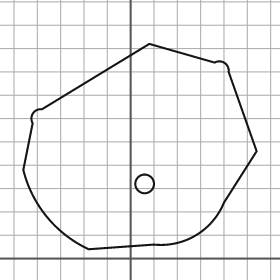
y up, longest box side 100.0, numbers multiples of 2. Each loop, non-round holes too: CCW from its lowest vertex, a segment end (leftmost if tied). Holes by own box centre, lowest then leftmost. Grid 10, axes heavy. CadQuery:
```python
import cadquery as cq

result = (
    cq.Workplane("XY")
    .moveTo(-18.0, 4.0)
    .lineTo(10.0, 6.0)
    .threePointArc((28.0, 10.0), (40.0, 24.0))
    .lineTo(54.0, 46.0)
    .lineTo(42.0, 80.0)
    .threePointArc((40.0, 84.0), (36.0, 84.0))
    .lineTo(8.0, 92.0)
    .lineTo(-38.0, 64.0)
    .threePointArc((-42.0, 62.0), (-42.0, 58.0))
    .lineTo(-46.0, 38.0)
    .threePointArc((-36.0, 18.0), (-18.0, 4.0))
    .close()
    .moveTo(6.0, 32.0)
    .circle(4.0)
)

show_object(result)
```